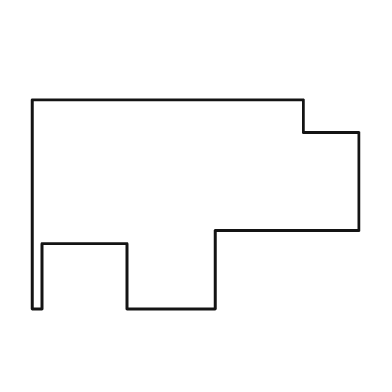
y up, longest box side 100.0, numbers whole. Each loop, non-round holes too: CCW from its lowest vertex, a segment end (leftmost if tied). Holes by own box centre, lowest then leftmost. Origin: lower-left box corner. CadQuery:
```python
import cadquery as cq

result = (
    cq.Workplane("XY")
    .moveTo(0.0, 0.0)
    .lineTo(3.0, 0.0)
    .lineTo(3.0, 20.0)
    .lineTo(29.0, 20.0)
    .lineTo(29.0, 0.0)
    .lineTo(56.0, 0.0)
    .lineTo(56.0, 24.0)
    .lineTo(100.0, 24.0)
    .lineTo(100.0, 54.0)
    .lineTo(83.0, 54.0)
    .lineTo(83.0, 64.0)
    .lineTo(0.0, 64.0)
    .close()
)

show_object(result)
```